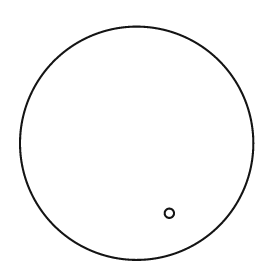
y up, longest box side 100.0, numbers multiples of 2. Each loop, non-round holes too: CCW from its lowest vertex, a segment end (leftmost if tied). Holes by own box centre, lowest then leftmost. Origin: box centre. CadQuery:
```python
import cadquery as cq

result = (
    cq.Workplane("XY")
    .moveTo(0.0, 0.0)
    .circle(50.0)
    .moveTo(14.0, -30.0)
    .circle(2.0)
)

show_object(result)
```